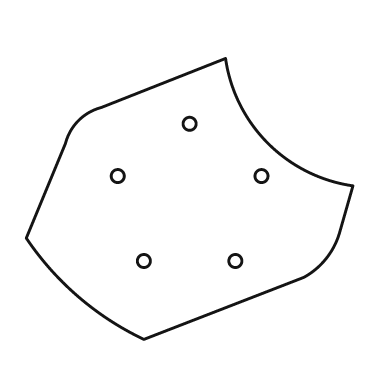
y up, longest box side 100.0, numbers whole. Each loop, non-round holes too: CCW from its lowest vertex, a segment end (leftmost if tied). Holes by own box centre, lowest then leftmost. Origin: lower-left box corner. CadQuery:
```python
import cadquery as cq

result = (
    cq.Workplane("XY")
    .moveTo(36.0, 0.0)
    .lineTo(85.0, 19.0)
    .threePointArc((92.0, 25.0), (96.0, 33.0))
    .lineTo(100.0, 47.0)
    .threePointArc((74.0, 60.0), (61.0, 86.0))
    .lineTo(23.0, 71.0)
    .threePointArc((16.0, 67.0), (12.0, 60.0))
    .lineTo(0.0, 31.0)
    .threePointArc((16.0, 13.0), (36.0, 0.0))
    .close()
    .moveTo(36.0, 24.0)
    .circle(2.0)
    .moveTo(64.0, 24.0)
    .circle(2.0)
    .moveTo(28.0, 50.0)
    .circle(2.0)
    .moveTo(72.0, 50.0)
    .circle(2.0)
    .moveTo(50.0, 66.0)
    .circle(2.0)
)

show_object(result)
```